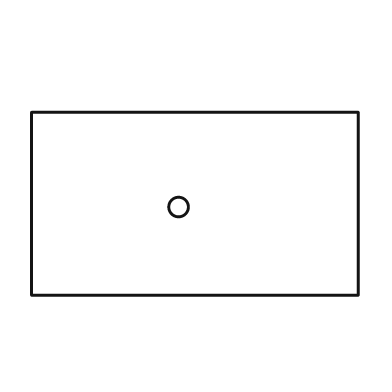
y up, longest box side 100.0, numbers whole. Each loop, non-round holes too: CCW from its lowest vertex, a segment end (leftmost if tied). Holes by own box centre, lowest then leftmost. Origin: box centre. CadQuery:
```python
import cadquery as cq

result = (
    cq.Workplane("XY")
    .moveTo(-50.0, -28.0)
    .lineTo(50.0, -28.0)
    .lineTo(50.0, 28.0)
    .lineTo(-50.0, 28.0)
    .close()
    .moveTo(-5.0, -1.0)
    .circle(3.0)
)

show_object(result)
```